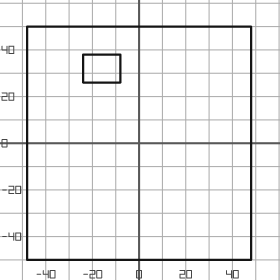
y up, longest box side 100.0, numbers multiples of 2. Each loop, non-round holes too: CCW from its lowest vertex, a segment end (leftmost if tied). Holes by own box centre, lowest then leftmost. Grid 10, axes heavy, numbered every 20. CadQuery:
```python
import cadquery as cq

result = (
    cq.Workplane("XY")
    .moveTo(-48.0, -50.0)
    .lineTo(48.0, -50.0)
    .lineTo(48.0, 50.0)
    .lineTo(-48.0, 50.0)
    .close()
    .moveTo(-24.0, 26.0)
    .lineTo(-8.0, 26.0)
    .lineTo(-8.0, 38.0)
    .lineTo(-24.0, 38.0)
    .close()
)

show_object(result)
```